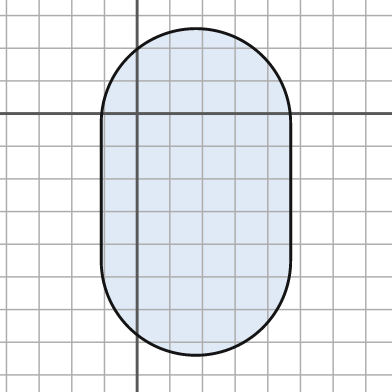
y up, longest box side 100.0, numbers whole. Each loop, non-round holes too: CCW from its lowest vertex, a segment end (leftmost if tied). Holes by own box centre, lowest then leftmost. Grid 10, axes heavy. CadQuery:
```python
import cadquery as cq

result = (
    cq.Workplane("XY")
    .moveTo(-11.0, -45.0)
    .threePointArc((18.0, -74.0), (47.0, -45.0))
    .lineTo(47.0, -3.0)
    .threePointArc((18.0, 26.0), (-11.0, -3.0))
    .close()
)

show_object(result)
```